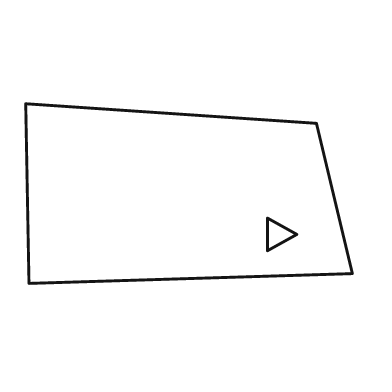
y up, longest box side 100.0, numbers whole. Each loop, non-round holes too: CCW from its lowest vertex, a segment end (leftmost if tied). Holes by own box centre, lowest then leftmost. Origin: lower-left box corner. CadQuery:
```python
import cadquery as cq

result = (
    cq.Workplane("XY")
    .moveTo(1.0, 0.0)
    .lineTo(100.0, 3.0)
    .lineTo(89.0, 49.0)
    .lineTo(0.0, 55.0)
    .close()
    .moveTo(74.0, 10.0)
    .lineTo(83.0, 15.0)
    .lineTo(74.0, 20.0)
    .close()
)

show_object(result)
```